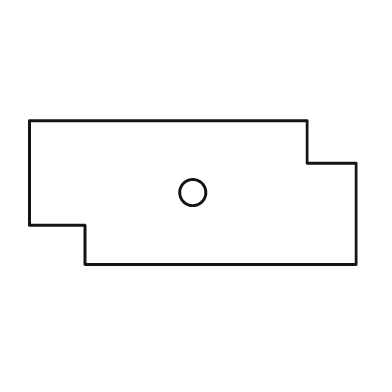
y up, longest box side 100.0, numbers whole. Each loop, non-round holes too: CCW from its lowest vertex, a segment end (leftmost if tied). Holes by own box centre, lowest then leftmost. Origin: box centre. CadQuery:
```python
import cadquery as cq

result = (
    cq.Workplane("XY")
    .moveTo(-33.0, -22.0)
    .lineTo(50.0, -22.0)
    .lineTo(50.0, 9.0)
    .lineTo(35.0, 9.0)
    .lineTo(35.0, 22.0)
    .lineTo(-50.0, 22.0)
    .lineTo(-50.0, -10.0)
    .lineTo(-33.0, -10.0)
    .close()
    .moveTo(0.0, 0.0)
    .circle(4.0)
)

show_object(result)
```